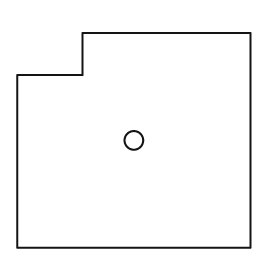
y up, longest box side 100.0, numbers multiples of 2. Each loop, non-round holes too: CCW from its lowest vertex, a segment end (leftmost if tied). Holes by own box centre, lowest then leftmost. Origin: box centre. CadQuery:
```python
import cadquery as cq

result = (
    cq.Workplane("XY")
    .moveTo(-50.0, -46.0)
    .lineTo(50.0, -46.0)
    .lineTo(50.0, 46.0)
    .lineTo(-22.0, 46.0)
    .lineTo(-22.0, 28.0)
    .lineTo(-50.0, 28.0)
    .close()
    .moveTo(0.0, 0.0)
    .circle(4.0)
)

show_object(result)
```